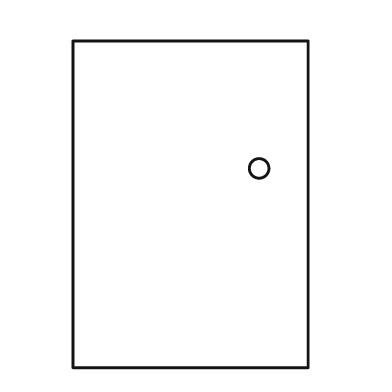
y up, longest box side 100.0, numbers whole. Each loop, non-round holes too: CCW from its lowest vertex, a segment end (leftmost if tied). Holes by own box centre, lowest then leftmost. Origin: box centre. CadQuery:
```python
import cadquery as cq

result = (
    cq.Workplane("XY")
    .moveTo(-36.0, -50.0)
    .lineTo(36.0, -50.0)
    .lineTo(36.0, 50.0)
    .lineTo(-36.0, 50.0)
    .close()
    .moveTo(21.0, 11.0)
    .circle(3.0)
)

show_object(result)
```